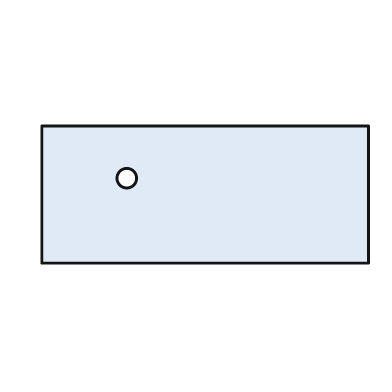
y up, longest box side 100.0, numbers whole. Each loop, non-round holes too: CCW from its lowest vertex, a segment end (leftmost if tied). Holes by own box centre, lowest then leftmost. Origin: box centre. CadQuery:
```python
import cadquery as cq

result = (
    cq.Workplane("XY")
    .moveTo(-50.0, -21.0)
    .lineTo(50.0, -21.0)
    .lineTo(50.0, 21.0)
    .lineTo(-50.0, 21.0)
    .close()
    .moveTo(-24.0, 5.0)
    .circle(3.0)
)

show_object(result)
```